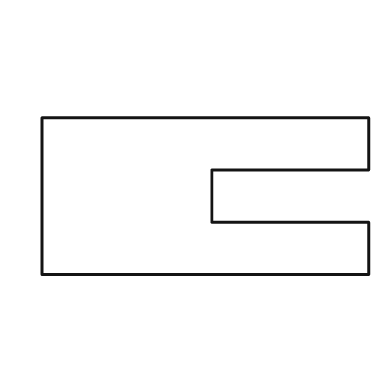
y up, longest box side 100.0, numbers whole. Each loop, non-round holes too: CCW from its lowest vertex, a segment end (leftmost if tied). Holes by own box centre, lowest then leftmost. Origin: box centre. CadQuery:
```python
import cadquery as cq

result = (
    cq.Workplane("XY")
    .moveTo(-50.0, -24.0)
    .lineTo(50.0, -24.0)
    .lineTo(50.0, -8.0)
    .lineTo(2.0, -8.0)
    .lineTo(2.0, 8.0)
    .lineTo(50.0, 8.0)
    .lineTo(50.0, 24.0)
    .lineTo(-50.0, 24.0)
    .close()
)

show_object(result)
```